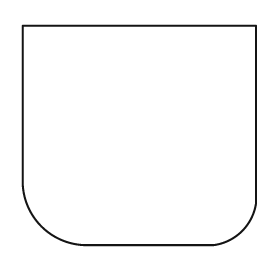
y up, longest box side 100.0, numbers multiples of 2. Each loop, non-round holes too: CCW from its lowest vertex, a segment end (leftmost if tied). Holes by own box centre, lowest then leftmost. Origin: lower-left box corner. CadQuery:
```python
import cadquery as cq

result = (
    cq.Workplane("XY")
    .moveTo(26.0, 0.0)
    .lineTo(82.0, 0.0)
    .threePointArc((94.0, 6.0), (100.0, 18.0))
    .lineTo(100.0, 94.0)
    .lineTo(0.0, 94.0)
    .lineTo(0.0, 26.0)
    .threePointArc((8.0, 8.0), (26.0, 0.0))
    .close()
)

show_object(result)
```